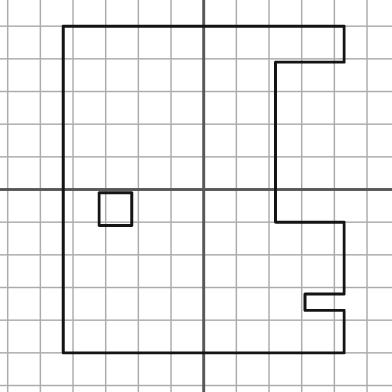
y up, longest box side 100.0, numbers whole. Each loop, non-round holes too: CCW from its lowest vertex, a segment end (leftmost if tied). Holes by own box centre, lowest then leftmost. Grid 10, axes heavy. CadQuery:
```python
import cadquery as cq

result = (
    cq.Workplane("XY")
    .moveTo(-43.0, -50.0)
    .lineTo(43.0, -50.0)
    .lineTo(43.0, -37.0)
    .lineTo(31.0, -37.0)
    .lineTo(31.0, -32.0)
    .lineTo(43.0, -32.0)
    .lineTo(43.0, -10.0)
    .lineTo(22.0, -10.0)
    .lineTo(22.0, 39.0)
    .lineTo(43.0, 39.0)
    .lineTo(43.0, 50.0)
    .lineTo(-43.0, 50.0)
    .close()
    .moveTo(-32.0, -11.0)
    .lineTo(-22.0, -11.0)
    .lineTo(-22.0, -1.0)
    .lineTo(-32.0, -1.0)
    .close()
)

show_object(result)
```